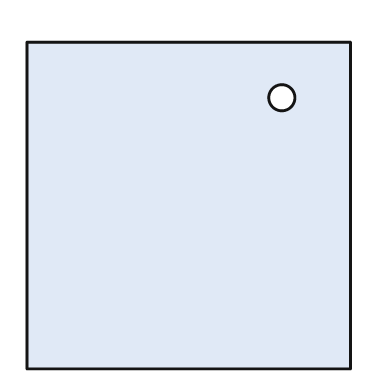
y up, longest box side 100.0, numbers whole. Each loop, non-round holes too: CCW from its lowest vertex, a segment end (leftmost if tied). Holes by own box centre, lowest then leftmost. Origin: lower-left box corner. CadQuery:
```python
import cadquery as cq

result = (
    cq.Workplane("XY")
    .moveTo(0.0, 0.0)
    .lineTo(99.0, 0.0)
    .lineTo(99.0, 100.0)
    .lineTo(0.0, 100.0)
    .close()
    .moveTo(78.0, 83.0)
    .circle(4.0)
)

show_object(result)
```